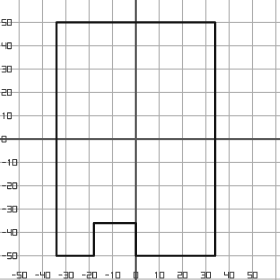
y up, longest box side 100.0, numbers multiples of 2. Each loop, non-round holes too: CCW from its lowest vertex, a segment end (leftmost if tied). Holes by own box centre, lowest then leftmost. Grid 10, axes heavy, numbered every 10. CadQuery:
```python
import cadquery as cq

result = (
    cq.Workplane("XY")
    .moveTo(-34.0, -50.0)
    .lineTo(-18.0, -50.0)
    .lineTo(-18.0, -36.0)
    .lineTo(0.0, -36.0)
    .lineTo(0.0, -50.0)
    .lineTo(34.0, -50.0)
    .lineTo(34.0, 50.0)
    .lineTo(-34.0, 50.0)
    .close()
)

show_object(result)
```